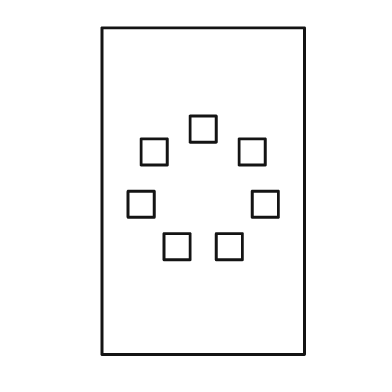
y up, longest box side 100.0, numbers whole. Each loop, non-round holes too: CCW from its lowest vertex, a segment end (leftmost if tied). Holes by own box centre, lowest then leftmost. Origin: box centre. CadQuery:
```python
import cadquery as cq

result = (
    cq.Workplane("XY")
    .moveTo(-31.0, -50.0)
    .lineTo(31.0, -50.0)
    .lineTo(31.0, 50.0)
    .lineTo(-31.0, 50.0)
    .close()
    .moveTo(-12.0, -21.0)
    .lineTo(-4.0, -21.0)
    .lineTo(-4.0, -13.0)
    .lineTo(-12.0, -13.0)
    .close()
    .moveTo(4.0, -21.0)
    .lineTo(12.0, -21.0)
    .lineTo(12.0, -13.0)
    .lineTo(4.0, -13.0)
    .close()
    .moveTo(-23.0, -8.0)
    .lineTo(-15.0, -8.0)
    .lineTo(-15.0, 0.0)
    .lineTo(-23.0, 0.0)
    .close()
    .moveTo(15.0, -8.0)
    .lineTo(23.0, -8.0)
    .lineTo(23.0, 0.0)
    .lineTo(15.0, 0.0)
    .close()
    .moveTo(-19.0, 8.0)
    .lineTo(-11.0, 8.0)
    .lineTo(-11.0, 16.0)
    .lineTo(-19.0, 16.0)
    .close()
    .moveTo(11.0, 8.0)
    .lineTo(19.0, 8.0)
    .lineTo(19.0, 16.0)
    .lineTo(11.0, 16.0)
    .close()
    .moveTo(-4.0, 15.0)
    .lineTo(4.0, 15.0)
    .lineTo(4.0, 23.0)
    .lineTo(-4.0, 23.0)
    .close()
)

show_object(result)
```